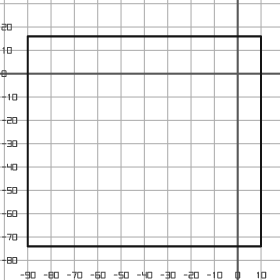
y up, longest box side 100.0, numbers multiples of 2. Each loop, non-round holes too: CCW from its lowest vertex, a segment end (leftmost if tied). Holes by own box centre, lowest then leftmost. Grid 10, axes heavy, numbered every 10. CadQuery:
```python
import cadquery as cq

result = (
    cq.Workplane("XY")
    .moveTo(-90.0, -74.0)
    .lineTo(10.0, -74.0)
    .lineTo(10.0, 16.0)
    .lineTo(-90.0, 16.0)
    .close()
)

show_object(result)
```